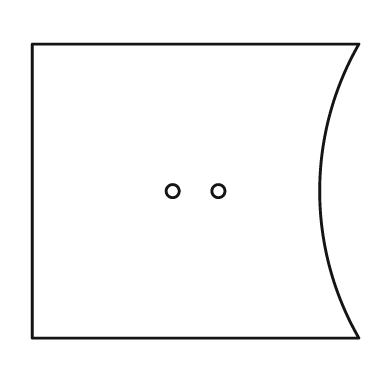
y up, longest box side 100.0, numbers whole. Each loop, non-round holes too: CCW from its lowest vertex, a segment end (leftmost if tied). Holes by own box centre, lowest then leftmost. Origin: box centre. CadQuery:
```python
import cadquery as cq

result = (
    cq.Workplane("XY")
    .moveTo(-50.0, -45.0)
    .lineTo(50.0, -45.0)
    .threePointArc((38.0, 0.0), (50.0, 45.0))
    .lineTo(-50.0, 45.0)
    .close()
    .moveTo(-7.0, 0.0)
    .circle(2.0)
    .moveTo(7.0, 0.0)
    .circle(2.0)
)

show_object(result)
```